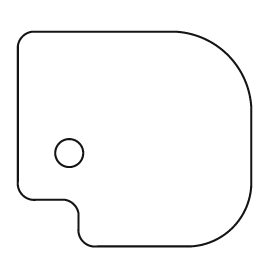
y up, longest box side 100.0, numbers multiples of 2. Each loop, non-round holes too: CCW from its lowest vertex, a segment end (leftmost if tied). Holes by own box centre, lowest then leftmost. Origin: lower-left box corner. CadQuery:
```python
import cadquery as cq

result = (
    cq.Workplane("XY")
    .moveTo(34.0, 0.0)
    .lineTo(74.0, 0.0)
    .threePointArc((92.0, 8.0), (100.0, 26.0))
    .lineTo(100.0, 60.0)
    .threePointArc((90.0, 82.0), (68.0, 92.0))
    .lineTo(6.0, 92.0)
    .threePointArc((2.0, 90.0), (0.0, 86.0))
    .lineTo(0.0, 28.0)
    .threePointArc((2.0, 22.0), (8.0, 20.0))
    .lineTo(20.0, 20.0)
    .threePointArc((24.0, 18.0), (26.0, 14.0))
    .lineTo(26.0, 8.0)
    .threePointArc((28.0, 2.0), (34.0, 0.0))
    .close()
    .moveTo(22.0, 40.0)
    .circle(6.0)
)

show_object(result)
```